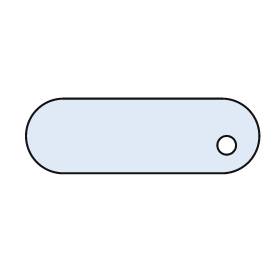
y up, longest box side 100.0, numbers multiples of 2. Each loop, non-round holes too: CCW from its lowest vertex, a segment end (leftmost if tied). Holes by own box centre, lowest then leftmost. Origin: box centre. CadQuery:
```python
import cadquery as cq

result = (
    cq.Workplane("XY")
    .moveTo(-34.0, -16.0)
    .lineTo(34.0, -16.0)
    .threePointArc((50.0, 0.0), (34.0, 16.0))
    .lineTo(-34.0, 16.0)
    .threePointArc((-50.0, 0.0), (-34.0, -16.0))
    .close()
    .moveTo(36.0, -4.0)
    .circle(4.0)
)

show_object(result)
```